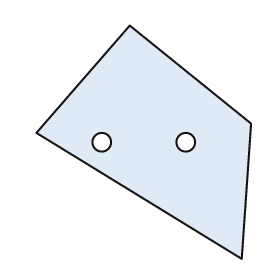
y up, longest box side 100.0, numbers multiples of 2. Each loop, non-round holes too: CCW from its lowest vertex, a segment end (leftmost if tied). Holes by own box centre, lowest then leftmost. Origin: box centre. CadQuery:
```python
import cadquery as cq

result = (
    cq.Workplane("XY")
    .moveTo(42.0, -50.0)
    .lineTo(46.0, 8.0)
    .lineTo(-6.0, 50.0)
    .lineTo(-46.0, 4.0)
    .close()
    .moveTo(-18.0, 0.0)
    .circle(4.0)
    .moveTo(18.0, 0.0)
    .circle(4.0)
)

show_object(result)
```